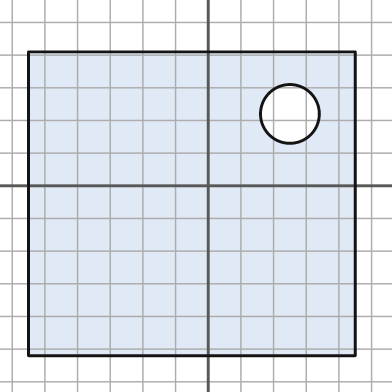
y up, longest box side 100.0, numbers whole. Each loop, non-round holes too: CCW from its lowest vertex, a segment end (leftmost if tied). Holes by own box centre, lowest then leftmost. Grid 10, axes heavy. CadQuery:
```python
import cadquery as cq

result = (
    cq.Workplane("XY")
    .moveTo(-55.0, -52.0)
    .lineTo(45.0, -52.0)
    .lineTo(45.0, 41.0)
    .lineTo(-55.0, 41.0)
    .close()
    .moveTo(25.0, 22.0)
    .circle(9.0)
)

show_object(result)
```